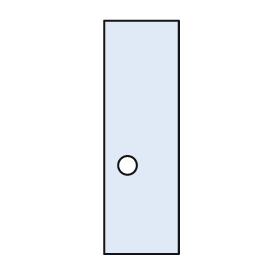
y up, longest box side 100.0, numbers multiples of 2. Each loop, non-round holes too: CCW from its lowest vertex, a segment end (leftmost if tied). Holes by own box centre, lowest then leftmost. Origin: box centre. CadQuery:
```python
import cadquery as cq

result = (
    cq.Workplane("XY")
    .moveTo(-16.0, -50.0)
    .lineTo(16.0, -50.0)
    .lineTo(16.0, 50.0)
    .lineTo(-16.0, 50.0)
    .close()
    .moveTo(-6.0, -12.0)
    .circle(4.0)
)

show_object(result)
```